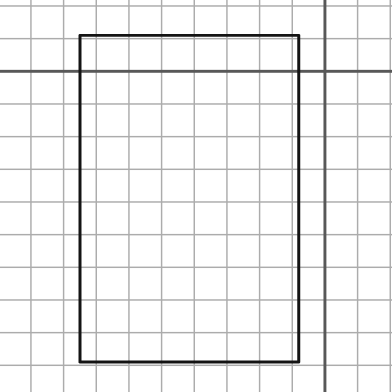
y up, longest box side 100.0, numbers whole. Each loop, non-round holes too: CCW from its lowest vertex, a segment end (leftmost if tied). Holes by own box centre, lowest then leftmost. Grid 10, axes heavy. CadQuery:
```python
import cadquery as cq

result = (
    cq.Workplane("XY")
    .moveTo(-75.0, -89.0)
    .lineTo(-8.0, -89.0)
    .lineTo(-8.0, 11.0)
    .lineTo(-75.0, 11.0)
    .close()
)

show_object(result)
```